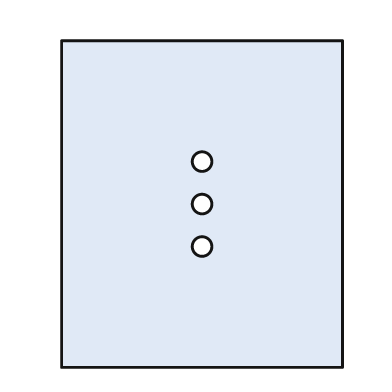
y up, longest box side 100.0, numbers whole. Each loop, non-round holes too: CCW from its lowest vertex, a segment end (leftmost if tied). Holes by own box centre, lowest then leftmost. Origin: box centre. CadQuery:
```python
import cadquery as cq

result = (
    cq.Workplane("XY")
    .moveTo(-43.0, -50.0)
    .lineTo(43.0, -50.0)
    .lineTo(43.0, 50.0)
    .lineTo(-43.0, 50.0)
    .close()
    .moveTo(0.0, -13.0)
    .circle(3.0)
    .moveTo(0.0, 0.0)
    .circle(3.0)
    .moveTo(0.0, 13.0)
    .circle(3.0)
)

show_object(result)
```